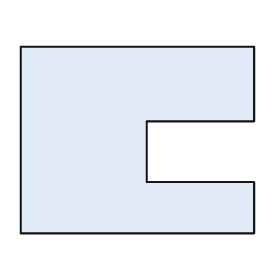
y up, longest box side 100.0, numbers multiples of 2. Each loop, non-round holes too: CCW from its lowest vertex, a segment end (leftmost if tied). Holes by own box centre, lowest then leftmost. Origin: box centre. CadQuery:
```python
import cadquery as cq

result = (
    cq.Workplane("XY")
    .moveTo(-50.0, -40.0)
    .lineTo(50.0, -40.0)
    .lineTo(50.0, -18.0)
    .lineTo(4.0, -18.0)
    .lineTo(4.0, 8.0)
    .lineTo(50.0, 8.0)
    .lineTo(50.0, 40.0)
    .lineTo(-50.0, 40.0)
    .close()
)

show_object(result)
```